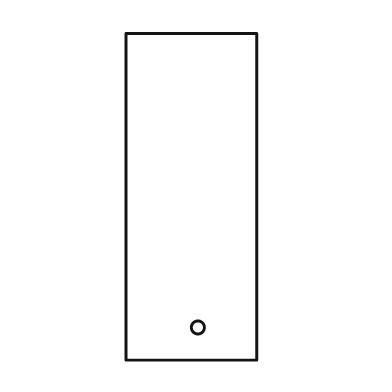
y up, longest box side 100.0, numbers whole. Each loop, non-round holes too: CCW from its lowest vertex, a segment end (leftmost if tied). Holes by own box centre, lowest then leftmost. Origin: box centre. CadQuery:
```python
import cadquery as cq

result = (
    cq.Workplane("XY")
    .moveTo(-20.0, -50.0)
    .lineTo(20.0, -50.0)
    .lineTo(20.0, 50.0)
    .lineTo(-20.0, 50.0)
    .close()
    .moveTo(2.0, -40.0)
    .circle(2.0)
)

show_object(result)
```